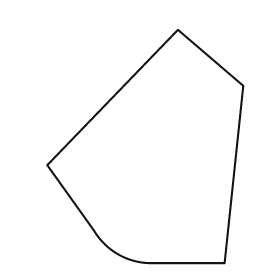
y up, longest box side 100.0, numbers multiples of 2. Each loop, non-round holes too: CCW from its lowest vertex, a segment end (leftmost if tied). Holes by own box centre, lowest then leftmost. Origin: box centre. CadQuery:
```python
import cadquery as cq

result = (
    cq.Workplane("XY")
    .moveTo(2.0, -50.0)
    .lineTo(34.0, -50.0)
    .lineTo(42.0, 26.0)
    .lineTo(14.0, 50.0)
    .lineTo(-42.0, -8.0)
    .lineTo(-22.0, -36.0)
    .threePointArc((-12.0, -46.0), (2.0, -50.0))
    .close()
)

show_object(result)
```